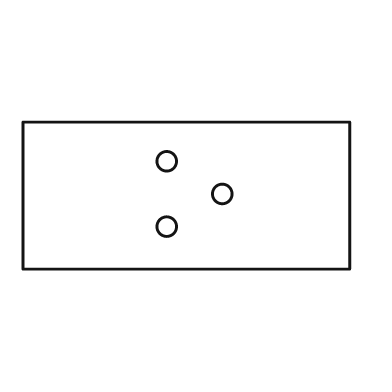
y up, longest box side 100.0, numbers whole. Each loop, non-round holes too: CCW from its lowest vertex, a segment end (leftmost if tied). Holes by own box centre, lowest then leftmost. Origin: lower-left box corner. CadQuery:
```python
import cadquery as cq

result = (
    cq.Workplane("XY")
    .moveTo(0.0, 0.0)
    .lineTo(100.0, 0.0)
    .lineTo(100.0, 45.0)
    .lineTo(0.0, 45.0)
    .close()
    .moveTo(44.0, 13.0)
    .circle(3.0)
    .moveTo(61.0, 23.0)
    .circle(3.0)
    .moveTo(44.0, 33.0)
    .circle(3.0)
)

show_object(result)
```